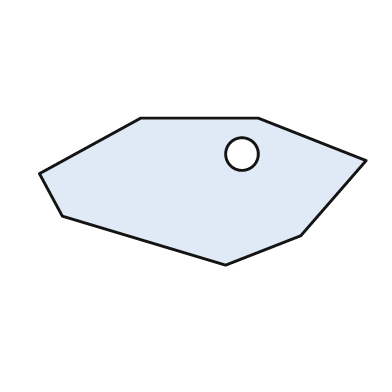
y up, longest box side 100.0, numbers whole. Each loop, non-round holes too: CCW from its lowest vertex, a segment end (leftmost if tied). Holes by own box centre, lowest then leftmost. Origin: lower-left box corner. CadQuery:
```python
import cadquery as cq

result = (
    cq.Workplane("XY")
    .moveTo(57.0, 0.0)
    .lineTo(80.0, 9.0)
    .lineTo(100.0, 32.0)
    .lineTo(67.0, 45.0)
    .lineTo(31.0, 45.0)
    .lineTo(0.0, 28.0)
    .lineTo(7.0, 15.0)
    .close()
    .moveTo(62.0, 34.0)
    .circle(5.0)
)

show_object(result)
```